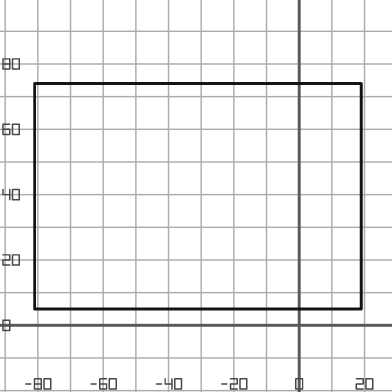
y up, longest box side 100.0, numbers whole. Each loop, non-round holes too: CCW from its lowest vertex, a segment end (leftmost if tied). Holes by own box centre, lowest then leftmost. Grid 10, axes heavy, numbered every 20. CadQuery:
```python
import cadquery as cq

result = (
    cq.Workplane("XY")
    .moveTo(-81.0, 5.0)
    .lineTo(19.0, 5.0)
    .lineTo(19.0, 74.0)
    .lineTo(-81.0, 74.0)
    .close()
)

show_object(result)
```